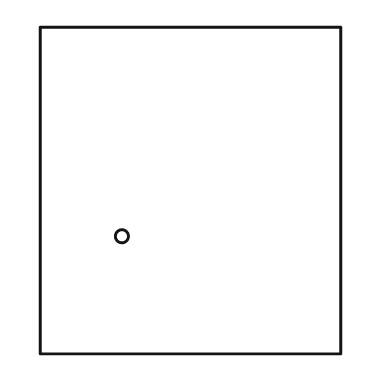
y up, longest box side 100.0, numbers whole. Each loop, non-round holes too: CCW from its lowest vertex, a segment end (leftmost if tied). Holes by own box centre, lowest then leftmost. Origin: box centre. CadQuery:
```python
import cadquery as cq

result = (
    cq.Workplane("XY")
    .moveTo(-46.0, -50.0)
    .lineTo(46.0, -50.0)
    .lineTo(46.0, 50.0)
    .lineTo(-46.0, 50.0)
    .close()
    .moveTo(-21.0, -14.0)
    .circle(2.0)
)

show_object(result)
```